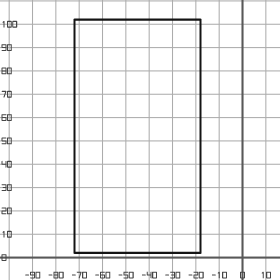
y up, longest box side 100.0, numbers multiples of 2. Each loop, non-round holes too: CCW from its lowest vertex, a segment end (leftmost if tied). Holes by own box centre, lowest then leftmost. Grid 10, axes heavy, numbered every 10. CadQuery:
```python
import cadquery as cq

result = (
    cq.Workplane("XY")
    .moveTo(-72.0, 2.0)
    .lineTo(-18.0, 2.0)
    .lineTo(-18.0, 102.0)
    .lineTo(-72.0, 102.0)
    .close()
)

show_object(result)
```